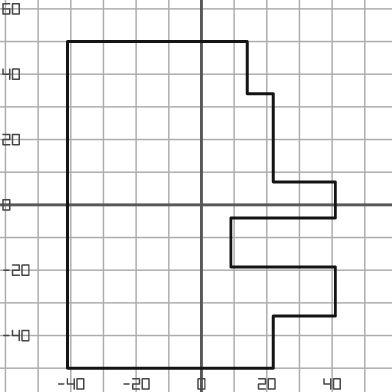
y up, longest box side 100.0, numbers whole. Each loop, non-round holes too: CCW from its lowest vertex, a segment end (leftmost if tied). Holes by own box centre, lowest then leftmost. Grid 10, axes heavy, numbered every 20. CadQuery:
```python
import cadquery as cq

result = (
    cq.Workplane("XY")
    .moveTo(-41.0, -50.0)
    .lineTo(22.0, -50.0)
    .lineTo(22.0, -34.0)
    .lineTo(41.0, -34.0)
    .lineTo(41.0, -19.0)
    .lineTo(9.0, -19.0)
    .lineTo(9.0, -4.0)
    .lineTo(41.0, -4.0)
    .lineTo(41.0, 7.0)
    .lineTo(22.0, 7.0)
    .lineTo(22.0, 34.0)
    .lineTo(14.0, 34.0)
    .lineTo(14.0, 50.0)
    .lineTo(-41.0, 50.0)
    .close()
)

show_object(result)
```